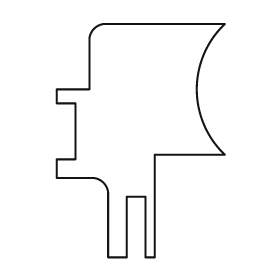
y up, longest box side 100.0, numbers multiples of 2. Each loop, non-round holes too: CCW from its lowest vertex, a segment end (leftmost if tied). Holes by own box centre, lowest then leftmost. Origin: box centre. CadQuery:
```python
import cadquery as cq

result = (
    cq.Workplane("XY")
    .moveTo(-14.0, -50.0)
    .lineTo(-6.0, -50.0)
    .lineTo(-6.0, -24.0)
    .lineTo(2.0, -24.0)
    .lineTo(2.0, -50.0)
    .lineTo(6.0, -50.0)
    .lineTo(6.0, -6.0)
    .lineTo(36.0, -6.0)
    .threePointArc((24.0, 22.0), (36.0, 50.0))
    .lineTo(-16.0, 50.0)
    .threePointArc((-20.0, 48.0), (-22.0, 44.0))
    .lineTo(-22.0, 22.0)
    .lineTo(-36.0, 22.0)
    .lineTo(-36.0, 16.0)
    .lineTo(-28.0, 16.0)
    .lineTo(-28.0, -8.0)
    .lineTo(-36.0, -8.0)
    .lineTo(-36.0, -16.0)
    .lineTo(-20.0, -16.0)
    .threePointArc((-16.0, -18.0), (-14.0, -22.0))
    .close()
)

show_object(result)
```